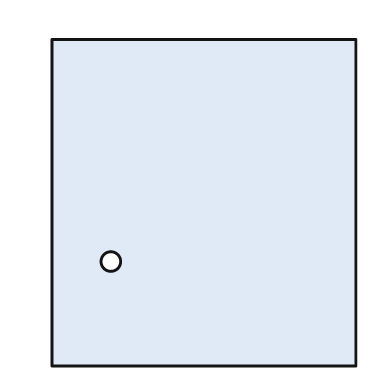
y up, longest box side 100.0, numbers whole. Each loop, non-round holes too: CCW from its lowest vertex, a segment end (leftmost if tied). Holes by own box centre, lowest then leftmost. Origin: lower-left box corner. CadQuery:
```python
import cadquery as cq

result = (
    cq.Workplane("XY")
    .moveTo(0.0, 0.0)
    .lineTo(93.0, 0.0)
    .lineTo(93.0, 100.0)
    .lineTo(0.0, 100.0)
    .close()
    .moveTo(18.0, 32.0)
    .circle(3.0)
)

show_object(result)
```